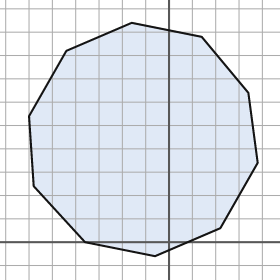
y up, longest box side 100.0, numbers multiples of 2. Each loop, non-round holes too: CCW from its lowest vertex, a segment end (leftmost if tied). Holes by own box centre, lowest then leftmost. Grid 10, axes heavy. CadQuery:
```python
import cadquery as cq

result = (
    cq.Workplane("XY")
    .moveTo(-6.0, -6.0)
    .lineTo(22.0, 6.0)
    .lineTo(38.0, 34.0)
    .lineTo(34.0, 64.0)
    .lineTo(14.0, 88.0)
    .lineTo(-16.0, 94.0)
    .lineTo(-44.0, 82.0)
    .lineTo(-60.0, 54.0)
    .lineTo(-58.0, 24.0)
    .lineTo(-36.0, 0.0)
    .close()
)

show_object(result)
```